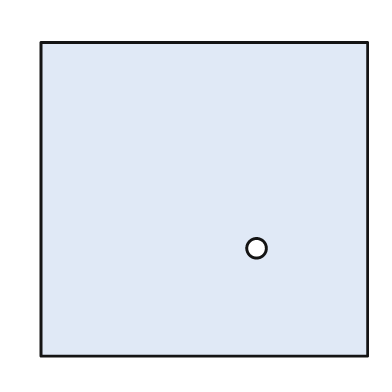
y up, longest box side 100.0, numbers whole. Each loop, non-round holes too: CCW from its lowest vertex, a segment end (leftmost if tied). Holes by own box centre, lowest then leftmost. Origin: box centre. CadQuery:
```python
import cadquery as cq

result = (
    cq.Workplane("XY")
    .moveTo(-50.0, -48.0)
    .lineTo(50.0, -48.0)
    .lineTo(50.0, 48.0)
    .lineTo(-50.0, 48.0)
    .close()
    .moveTo(16.0, -15.0)
    .circle(3.0)
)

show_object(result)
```